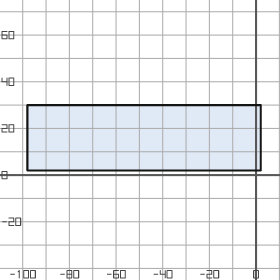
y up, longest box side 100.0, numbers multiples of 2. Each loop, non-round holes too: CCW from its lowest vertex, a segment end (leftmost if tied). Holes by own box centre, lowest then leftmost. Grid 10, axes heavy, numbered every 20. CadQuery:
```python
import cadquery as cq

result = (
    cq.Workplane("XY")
    .moveTo(-98.0, 2.0)
    .lineTo(2.0, 2.0)
    .lineTo(2.0, 30.0)
    .lineTo(-98.0, 30.0)
    .close()
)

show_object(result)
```